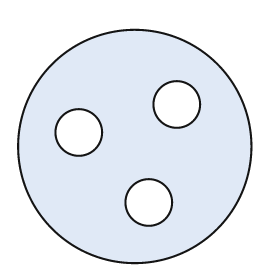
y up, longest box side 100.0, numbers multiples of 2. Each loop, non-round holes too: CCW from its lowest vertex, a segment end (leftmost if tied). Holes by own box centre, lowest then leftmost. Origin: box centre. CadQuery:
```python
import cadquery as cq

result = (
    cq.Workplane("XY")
    .moveTo(0.0, 0.0)
    .circle(50.0)
    .moveTo(6.0, -24.0)
    .circle(10.0)
    .moveTo(-24.0, 6.0)
    .circle(10.0)
    .moveTo(18.0, 18.0)
    .circle(10.0)
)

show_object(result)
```